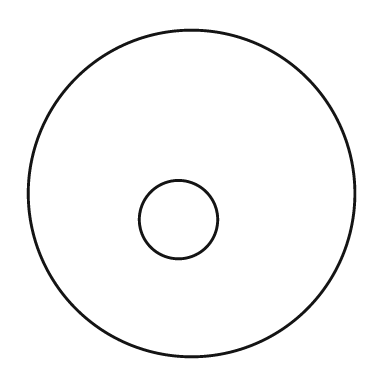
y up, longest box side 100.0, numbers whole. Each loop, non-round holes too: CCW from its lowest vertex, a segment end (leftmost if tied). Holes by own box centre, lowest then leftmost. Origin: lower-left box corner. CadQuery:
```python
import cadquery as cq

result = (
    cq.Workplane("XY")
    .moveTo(50.0, 50.0)
    .circle(50.0)
    .moveTo(46.0, 42.0)
    .circle(12.0)
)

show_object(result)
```